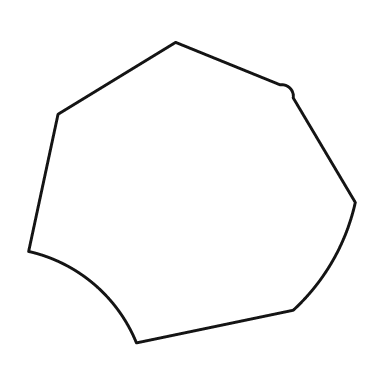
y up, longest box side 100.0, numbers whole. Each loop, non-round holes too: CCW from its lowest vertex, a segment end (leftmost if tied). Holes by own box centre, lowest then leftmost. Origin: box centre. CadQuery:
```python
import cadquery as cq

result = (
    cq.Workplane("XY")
    .moveTo(-17.0, -46.0)
    .lineTo(31.0, -36.0)
    .threePointArc((43.0, -21.0), (50.0, -3.0))
    .lineTo(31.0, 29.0)
    .threePointArc((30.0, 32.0), (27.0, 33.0))
    .lineTo(-5.0, 46.0)
    .lineTo(-41.0, 24.0)
    .lineTo(-50.0, -18.0)
    .threePointArc((-30.0, -28.0), (-17.0, -46.0))
    .close()
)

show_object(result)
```